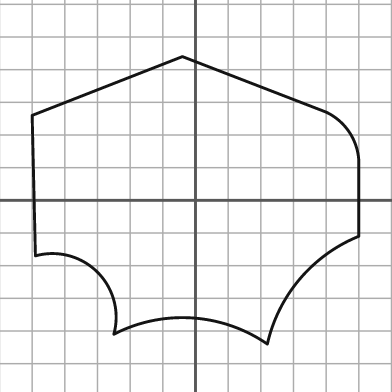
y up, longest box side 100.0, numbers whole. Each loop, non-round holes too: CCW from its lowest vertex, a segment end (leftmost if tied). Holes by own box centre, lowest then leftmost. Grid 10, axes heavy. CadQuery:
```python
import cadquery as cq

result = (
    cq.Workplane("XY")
    .moveTo(22.0, -44.0)
    .threePointArc((32.0, -24.0), (50.0, -11.0))
    .lineTo(50.0, 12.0)
    .threePointArc((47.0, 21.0), (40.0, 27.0))
    .lineTo(-4.0, 44.0)
    .lineTo(-50.0, 26.0)
    .lineTo(-49.0, -17.0)
    .threePointArc((-30.0, -22.0), (-25.0, -41.0))
    .threePointArc((-1.0, -36.0), (22.0, -44.0))
    .close()
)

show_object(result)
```